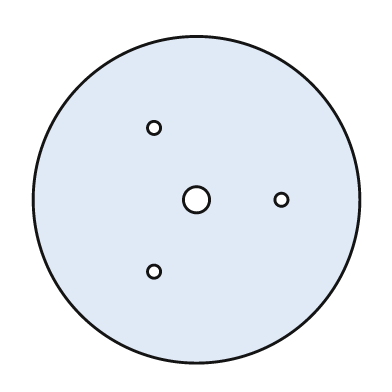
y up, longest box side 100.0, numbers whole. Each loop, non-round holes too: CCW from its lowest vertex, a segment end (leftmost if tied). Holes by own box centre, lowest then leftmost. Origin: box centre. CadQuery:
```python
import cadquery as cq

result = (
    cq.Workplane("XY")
    .moveTo(0.0, 0.0)
    .circle(50.0)
    .moveTo(-13.0, -22.0)
    .circle(2.0)
    .moveTo(0.0, 0.0)
    .circle(4.0)
    .moveTo(26.0, 0.0)
    .circle(2.0)
    .moveTo(-13.0, 22.0)
    .circle(2.0)
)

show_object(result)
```